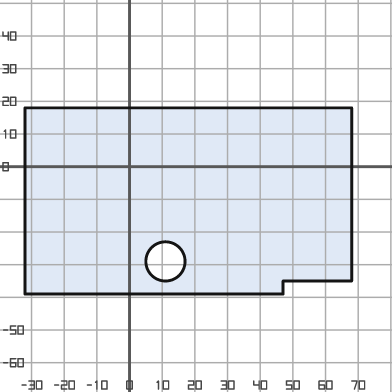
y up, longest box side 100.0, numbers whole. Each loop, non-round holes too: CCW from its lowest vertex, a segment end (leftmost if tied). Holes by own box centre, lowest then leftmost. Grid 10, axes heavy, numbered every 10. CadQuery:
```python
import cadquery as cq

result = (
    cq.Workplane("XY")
    .moveTo(-32.0, -39.0)
    .lineTo(47.0, -39.0)
    .lineTo(47.0, -35.0)
    .lineTo(68.0, -35.0)
    .lineTo(68.0, 18.0)
    .lineTo(-32.0, 18.0)
    .close()
    .moveTo(11.0, -29.0)
    .circle(6.0)
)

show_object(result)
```